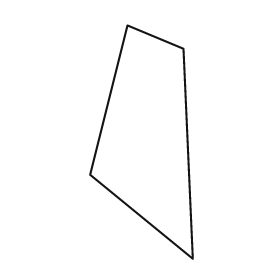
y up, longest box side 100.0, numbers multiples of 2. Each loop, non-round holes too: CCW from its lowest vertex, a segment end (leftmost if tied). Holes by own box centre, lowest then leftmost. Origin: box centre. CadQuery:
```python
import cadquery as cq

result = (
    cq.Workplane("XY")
    .moveTo(22.0, -50.0)
    .lineTo(18.0, 40.0)
    .lineTo(-6.0, 50.0)
    .lineTo(-22.0, -14.0)
    .close()
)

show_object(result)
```